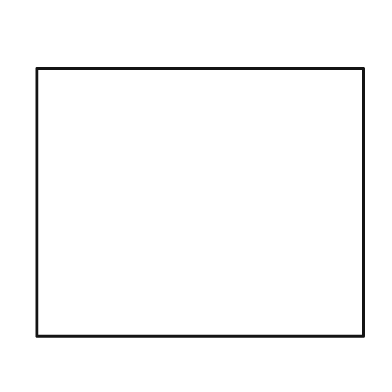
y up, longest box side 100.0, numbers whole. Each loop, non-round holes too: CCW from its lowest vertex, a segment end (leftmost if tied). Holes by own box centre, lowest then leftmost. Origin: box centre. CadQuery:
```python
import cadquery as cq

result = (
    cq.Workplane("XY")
    .moveTo(-50.0, -41.0)
    .lineTo(50.0, -41.0)
    .lineTo(50.0, 41.0)
    .lineTo(-50.0, 41.0)
    .close()
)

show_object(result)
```